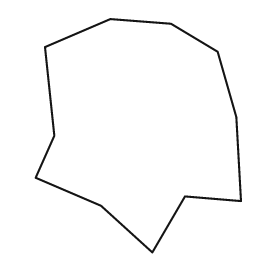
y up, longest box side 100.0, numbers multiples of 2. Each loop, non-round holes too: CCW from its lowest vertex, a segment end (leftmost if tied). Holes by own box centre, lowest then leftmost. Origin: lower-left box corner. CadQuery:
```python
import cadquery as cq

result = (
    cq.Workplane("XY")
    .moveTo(50.0, 0.0)
    .lineTo(64.0, 24.0)
    .lineTo(88.0, 22.0)
    .lineTo(86.0, 58.0)
    .lineTo(78.0, 86.0)
    .lineTo(58.0, 98.0)
    .lineTo(32.0, 100.0)
    .lineTo(4.0, 88.0)
    .lineTo(8.0, 50.0)
    .lineTo(0.0, 32.0)
    .lineTo(28.0, 20.0)
    .close()
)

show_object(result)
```